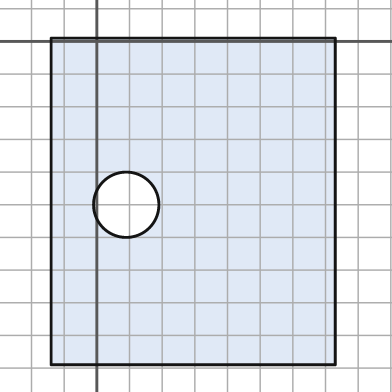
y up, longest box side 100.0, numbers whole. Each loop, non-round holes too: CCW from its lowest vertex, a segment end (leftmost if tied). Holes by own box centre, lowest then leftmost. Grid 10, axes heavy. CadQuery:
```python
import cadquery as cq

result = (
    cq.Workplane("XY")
    .moveTo(-14.0, -99.0)
    .lineTo(73.0, -99.0)
    .lineTo(73.0, 1.0)
    .lineTo(-14.0, 1.0)
    .close()
    .moveTo(9.0, -50.0)
    .circle(10.0)
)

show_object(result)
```